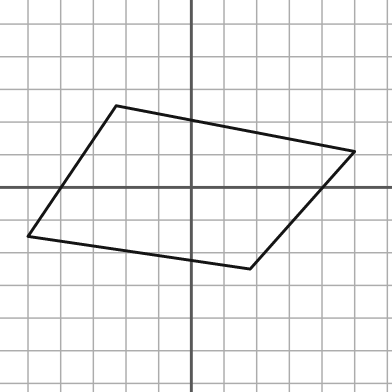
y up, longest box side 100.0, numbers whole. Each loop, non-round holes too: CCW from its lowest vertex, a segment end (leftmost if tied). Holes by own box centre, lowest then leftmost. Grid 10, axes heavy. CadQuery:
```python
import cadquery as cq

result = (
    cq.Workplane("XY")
    .moveTo(18.0, -25.0)
    .lineTo(50.0, 11.0)
    .lineTo(-23.0, 25.0)
    .lineTo(-50.0, -15.0)
    .close()
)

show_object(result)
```